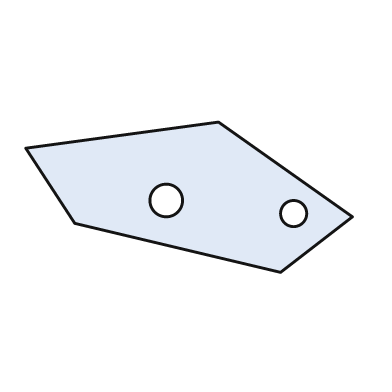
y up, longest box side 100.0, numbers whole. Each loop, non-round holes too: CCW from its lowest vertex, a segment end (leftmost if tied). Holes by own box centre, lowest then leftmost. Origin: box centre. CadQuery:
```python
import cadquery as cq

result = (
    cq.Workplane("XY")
    .moveTo(28.0, -23.0)
    .lineTo(50.0, -6.0)
    .lineTo(9.0, 23.0)
    .lineTo(-50.0, 15.0)
    .lineTo(-35.0, -8.0)
    .close()
    .moveTo(32.0, -5.0)
    .circle(4.0)
    .moveTo(-7.0, -1.0)
    .circle(5.0)
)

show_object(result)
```